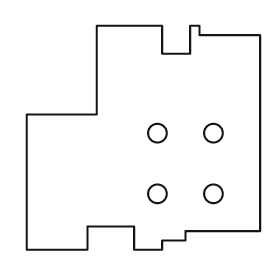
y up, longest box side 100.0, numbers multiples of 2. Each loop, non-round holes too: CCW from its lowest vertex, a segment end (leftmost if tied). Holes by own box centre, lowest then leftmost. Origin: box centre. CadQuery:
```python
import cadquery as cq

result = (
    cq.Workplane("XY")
    .moveTo(-50.0, -48.0)
    .lineTo(-24.0, -48.0)
    .lineTo(-24.0, -38.0)
    .lineTo(-4.0, -38.0)
    .lineTo(-4.0, -48.0)
    .lineTo(8.0, -48.0)
    .lineTo(8.0, -44.0)
    .lineTo(18.0, -44.0)
    .lineTo(18.0, -40.0)
    .lineTo(50.0, -40.0)
    .lineTo(50.0, 44.0)
    .lineTo(24.0, 44.0)
    .lineTo(24.0, 48.0)
    .lineTo(20.0, 48.0)
    .lineTo(20.0, 36.0)
    .lineTo(8.0, 36.0)
    .lineTo(8.0, 48.0)
    .lineTo(-20.0, 48.0)
    .lineTo(-20.0, 10.0)
    .lineTo(-50.0, 10.0)
    .close()
    .moveTo(6.0, -24.0)
    .circle(4.0)
    .moveTo(30.0, -24.0)
    .circle(4.0)
    .moveTo(6.0, 2.0)
    .circle(4.0)
    .moveTo(30.0, 2.0)
    .circle(4.0)
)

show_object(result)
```